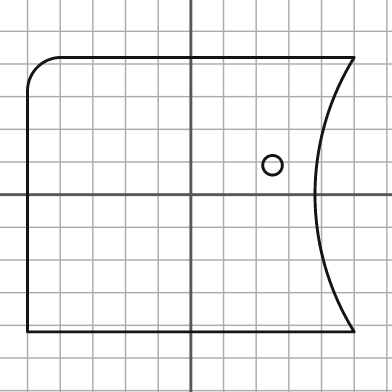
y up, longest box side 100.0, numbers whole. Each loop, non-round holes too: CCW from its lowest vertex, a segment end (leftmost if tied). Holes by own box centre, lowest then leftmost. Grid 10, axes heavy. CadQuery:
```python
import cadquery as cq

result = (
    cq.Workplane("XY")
    .moveTo(-50.0, -42.0)
    .lineTo(50.0, -42.0)
    .threePointArc((38.0, 0.0), (50.0, 42.0))
    .lineTo(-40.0, 42.0)
    .threePointArc((-47.0, 39.0), (-50.0, 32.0))
    .close()
    .moveTo(25.0, 9.0)
    .circle(3.0)
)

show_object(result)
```